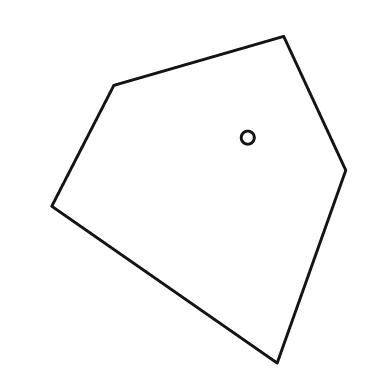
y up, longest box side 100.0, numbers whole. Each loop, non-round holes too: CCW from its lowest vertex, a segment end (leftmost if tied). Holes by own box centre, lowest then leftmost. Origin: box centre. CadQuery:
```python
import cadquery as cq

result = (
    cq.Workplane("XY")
    .moveTo(24.0, -50.0)
    .lineTo(45.0, 9.0)
    .lineTo(26.0, 50.0)
    .lineTo(-26.0, 35.0)
    .lineTo(-45.0, -2.0)
    .close()
    .moveTo(15.0, 19.0)
    .circle(2.0)
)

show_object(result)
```